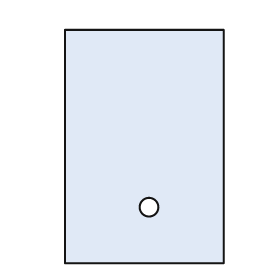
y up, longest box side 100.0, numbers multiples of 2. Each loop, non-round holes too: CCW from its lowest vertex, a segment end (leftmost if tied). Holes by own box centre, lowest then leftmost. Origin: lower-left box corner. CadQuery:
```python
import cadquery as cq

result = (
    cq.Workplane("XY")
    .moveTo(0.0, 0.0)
    .lineTo(68.0, 0.0)
    .lineTo(68.0, 100.0)
    .lineTo(0.0, 100.0)
    .close()
    .moveTo(36.0, 24.0)
    .circle(4.0)
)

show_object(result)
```